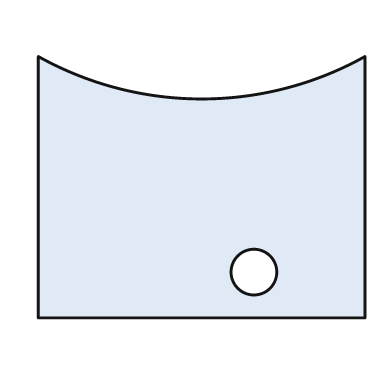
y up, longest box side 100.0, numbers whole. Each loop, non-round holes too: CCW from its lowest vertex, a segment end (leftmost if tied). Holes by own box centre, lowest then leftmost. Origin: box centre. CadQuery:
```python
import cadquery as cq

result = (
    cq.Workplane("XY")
    .moveTo(-50.0, -40.0)
    .lineTo(50.0, -40.0)
    .lineTo(50.0, 40.0)
    .threePointArc((0.0, 27.0), (-50.0, 40.0))
    .close()
    .moveTo(16.0, -26.0)
    .circle(7.0)
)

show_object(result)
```